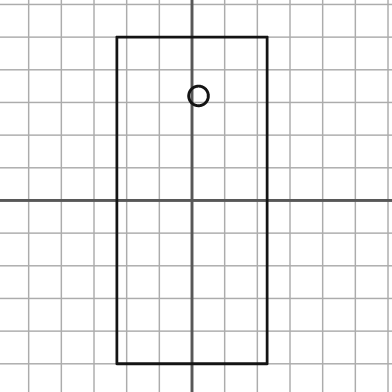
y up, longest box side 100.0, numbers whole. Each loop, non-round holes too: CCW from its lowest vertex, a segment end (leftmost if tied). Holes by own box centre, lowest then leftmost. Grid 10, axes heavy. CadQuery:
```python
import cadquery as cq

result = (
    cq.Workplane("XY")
    .moveTo(-23.0, -50.0)
    .lineTo(23.0, -50.0)
    .lineTo(23.0, 50.0)
    .lineTo(-23.0, 50.0)
    .close()
    .moveTo(2.0, 32.0)
    .circle(3.0)
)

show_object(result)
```